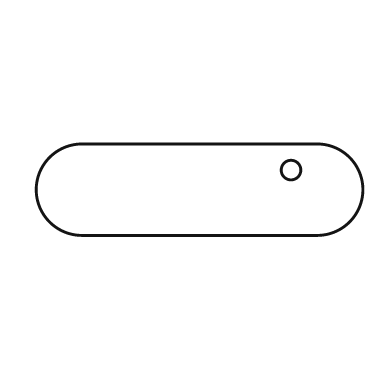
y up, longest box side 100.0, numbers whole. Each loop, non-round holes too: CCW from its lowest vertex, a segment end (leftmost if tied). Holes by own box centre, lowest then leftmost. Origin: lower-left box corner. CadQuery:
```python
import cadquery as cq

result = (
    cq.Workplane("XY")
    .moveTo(14.0, 0.0)
    .lineTo(86.0, 0.0)
    .threePointArc((100.0, 14.0), (86.0, 28.0))
    .lineTo(14.0, 28.0)
    .threePointArc((0.0, 14.0), (14.0, 0.0))
    .close()
    .moveTo(78.0, 20.0)
    .circle(3.0)
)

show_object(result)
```